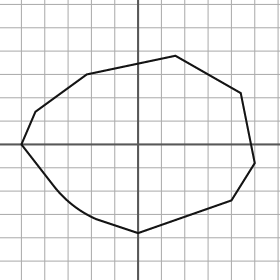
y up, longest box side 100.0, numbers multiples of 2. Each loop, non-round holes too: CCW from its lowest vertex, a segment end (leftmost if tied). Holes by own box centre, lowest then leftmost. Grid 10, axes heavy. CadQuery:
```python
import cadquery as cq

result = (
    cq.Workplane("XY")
    .moveTo(0.0, -38.0)
    .lineTo(40.0, -24.0)
    .lineTo(50.0, -8.0)
    .lineTo(44.0, 22.0)
    .lineTo(16.0, 38.0)
    .lineTo(-22.0, 30.0)
    .lineTo(-44.0, 14.0)
    .lineTo(-50.0, 0.0)
    .lineTo(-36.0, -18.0)
    .threePointArc((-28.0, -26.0), (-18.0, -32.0))
    .close()
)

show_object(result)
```